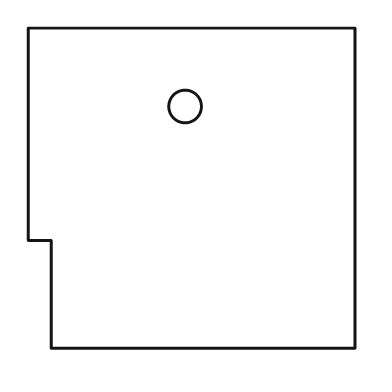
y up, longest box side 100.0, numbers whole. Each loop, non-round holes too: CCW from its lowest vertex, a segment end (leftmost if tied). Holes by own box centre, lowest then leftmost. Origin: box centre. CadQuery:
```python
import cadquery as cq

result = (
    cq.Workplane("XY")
    .moveTo(-43.0, -49.0)
    .lineTo(50.0, -49.0)
    .lineTo(50.0, 49.0)
    .lineTo(-50.0, 49.0)
    .lineTo(-50.0, -16.0)
    .lineTo(-43.0, -16.0)
    .close()
    .moveTo(-2.0, 25.0)
    .circle(5.0)
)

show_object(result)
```